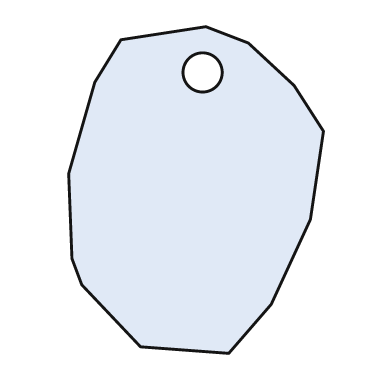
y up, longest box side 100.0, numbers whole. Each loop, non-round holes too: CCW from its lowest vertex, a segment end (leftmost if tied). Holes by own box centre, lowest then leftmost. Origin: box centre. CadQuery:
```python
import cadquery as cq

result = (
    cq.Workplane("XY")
    .moveTo(10.0, -50.0)
    .lineTo(23.0, -35.0)
    .lineTo(35.0, -9.0)
    .lineTo(39.0, 18.0)
    .lineTo(30.0, 32.0)
    .lineTo(16.0, 45.0)
    .lineTo(3.0, 50.0)
    .lineTo(-23.0, 46.0)
    .lineTo(-31.0, 33.0)
    .lineTo(-39.0, 5.0)
    .lineTo(-38.0, -21.0)
    .lineTo(-35.0, -29.0)
    .lineTo(-17.0, -48.0)
    .close()
    .moveTo(2.0, 36.0)
    .circle(6.0)
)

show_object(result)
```